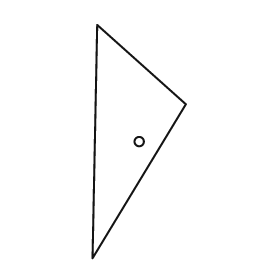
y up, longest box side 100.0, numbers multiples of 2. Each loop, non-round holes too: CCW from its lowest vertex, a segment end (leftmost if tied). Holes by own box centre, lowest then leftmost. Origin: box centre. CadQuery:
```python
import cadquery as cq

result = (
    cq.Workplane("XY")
    .moveTo(-20.0, -50.0)
    .lineTo(20.0, 16.0)
    .lineTo(-18.0, 50.0)
    .close()
    .moveTo(0.0, 0.0)
    .circle(2.0)
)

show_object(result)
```